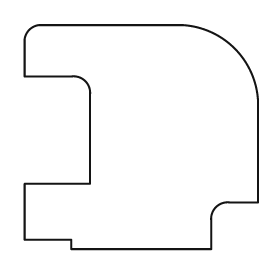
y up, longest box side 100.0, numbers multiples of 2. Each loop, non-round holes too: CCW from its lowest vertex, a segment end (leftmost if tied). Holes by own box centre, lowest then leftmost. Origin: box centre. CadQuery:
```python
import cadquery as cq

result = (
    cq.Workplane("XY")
    .moveTo(-30.0, -48.0)
    .lineTo(30.0, -48.0)
    .lineTo(30.0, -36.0)
    .threePointArc((32.0, -30.0), (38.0, -28.0))
    .lineTo(50.0, -28.0)
    .lineTo(50.0, 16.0)
    .threePointArc((40.0, 38.0), (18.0, 48.0))
    .lineTo(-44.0, 48.0)
    .threePointArc((-48.0, 46.0), (-50.0, 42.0))
    .lineTo(-50.0, 26.0)
    .lineTo(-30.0, 26.0)
    .threePointArc((-24.0, 24.0), (-22.0, 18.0))
    .lineTo(-22.0, -20.0)
    .lineTo(-50.0, -20.0)
    .lineTo(-50.0, -44.0)
    .lineTo(-30.0, -44.0)
    .close()
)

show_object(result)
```